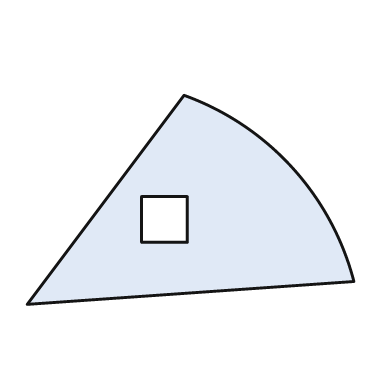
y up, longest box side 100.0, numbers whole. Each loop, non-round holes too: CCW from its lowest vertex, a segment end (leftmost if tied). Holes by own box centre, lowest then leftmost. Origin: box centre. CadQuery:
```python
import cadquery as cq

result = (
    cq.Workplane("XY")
    .moveTo(-50.0, -32.0)
    .lineTo(50.0, -25.0)
    .threePointArc((31.0, 10.0), (-2.0, 32.0))
    .close()
    .moveTo(-15.0, -13.0)
    .lineTo(-1.0, -13.0)
    .lineTo(-1.0, 1.0)
    .lineTo(-15.0, 1.0)
    .close()
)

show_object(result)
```